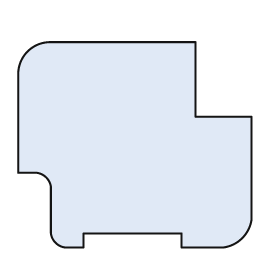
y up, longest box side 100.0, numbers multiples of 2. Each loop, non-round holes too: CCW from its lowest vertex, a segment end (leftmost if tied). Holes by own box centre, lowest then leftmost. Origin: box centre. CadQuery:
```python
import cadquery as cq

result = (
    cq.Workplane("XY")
    .moveTo(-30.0, -44.0)
    .lineTo(-22.0, -44.0)
    .lineTo(-22.0, -38.0)
    .lineTo(20.0, -38.0)
    .lineTo(20.0, -44.0)
    .lineTo(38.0, -44.0)
    .threePointArc((46.0, -40.0), (50.0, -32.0))
    .lineTo(50.0, 12.0)
    .lineTo(26.0, 12.0)
    .lineTo(26.0, 44.0)
    .lineTo(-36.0, 44.0)
    .threePointArc((-46.0, 40.0), (-50.0, 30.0))
    .lineTo(-50.0, -12.0)
    .lineTo(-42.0, -12.0)
    .threePointArc((-38.0, -14.0), (-36.0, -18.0))
    .lineTo(-36.0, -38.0)
    .threePointArc((-34.0, -42.0), (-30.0, -44.0))
    .close()
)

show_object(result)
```